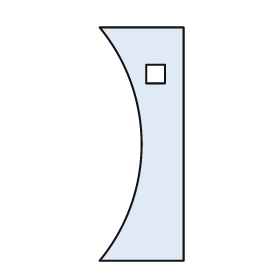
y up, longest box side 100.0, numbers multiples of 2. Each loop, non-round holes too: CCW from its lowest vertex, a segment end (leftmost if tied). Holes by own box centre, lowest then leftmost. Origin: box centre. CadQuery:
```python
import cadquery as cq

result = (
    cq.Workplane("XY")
    .moveTo(-18.0, -50.0)
    .lineTo(18.0, -50.0)
    .lineTo(18.0, 50.0)
    .lineTo(-18.0, 50.0)
    .threePointArc((0.0, 0.0), (-18.0, -50.0))
    .close()
    .moveTo(2.0, 26.0)
    .lineTo(10.0, 26.0)
    .lineTo(10.0, 34.0)
    .lineTo(2.0, 34.0)
    .close()
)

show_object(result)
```